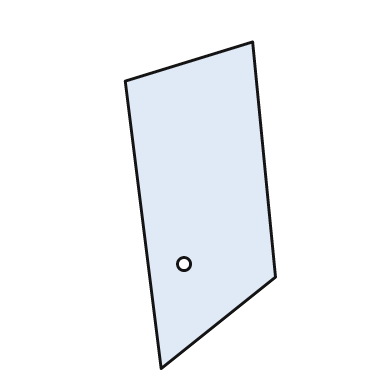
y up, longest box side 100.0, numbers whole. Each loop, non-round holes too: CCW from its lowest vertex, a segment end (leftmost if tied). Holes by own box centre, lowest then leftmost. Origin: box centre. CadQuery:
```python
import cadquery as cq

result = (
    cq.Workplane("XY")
    .moveTo(-12.0, -50.0)
    .lineTo(23.0, -22.0)
    .lineTo(16.0, 50.0)
    .lineTo(-23.0, 38.0)
    .close()
    .moveTo(-5.0, -18.0)
    .circle(2.0)
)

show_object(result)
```